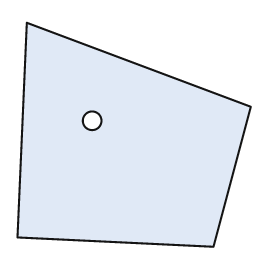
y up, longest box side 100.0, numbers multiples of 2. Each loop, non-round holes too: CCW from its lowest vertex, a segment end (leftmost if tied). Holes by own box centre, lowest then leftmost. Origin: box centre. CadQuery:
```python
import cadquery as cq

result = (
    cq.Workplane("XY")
    .moveTo(34.0, -48.0)
    .lineTo(50.0, 12.0)
    .lineTo(-46.0, 48.0)
    .lineTo(-50.0, -44.0)
    .close()
    .moveTo(-18.0, 6.0)
    .circle(4.0)
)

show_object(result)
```